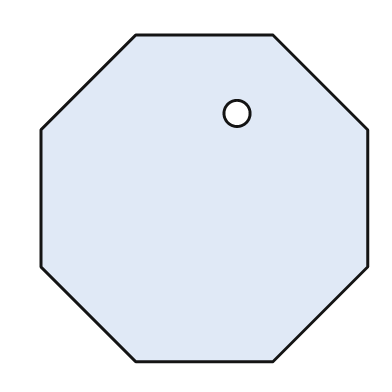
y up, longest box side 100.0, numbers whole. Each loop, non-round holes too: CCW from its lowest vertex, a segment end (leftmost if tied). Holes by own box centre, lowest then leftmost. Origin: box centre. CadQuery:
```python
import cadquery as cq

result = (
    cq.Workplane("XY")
    .moveTo(-21.0, -50.0)
    .lineTo(21.0, -50.0)
    .lineTo(50.0, -21.0)
    .lineTo(50.0, 21.0)
    .lineTo(21.0, 50.0)
    .lineTo(-21.0, 50.0)
    .lineTo(-50.0, 21.0)
    .lineTo(-50.0, -21.0)
    .close()
    .moveTo(10.0, 26.0)
    .circle(4.0)
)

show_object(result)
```